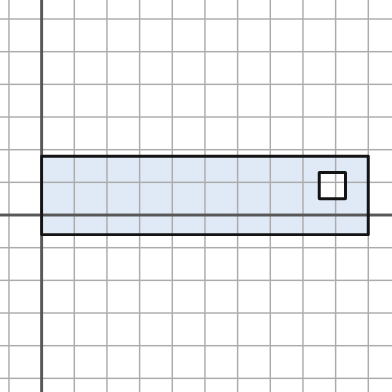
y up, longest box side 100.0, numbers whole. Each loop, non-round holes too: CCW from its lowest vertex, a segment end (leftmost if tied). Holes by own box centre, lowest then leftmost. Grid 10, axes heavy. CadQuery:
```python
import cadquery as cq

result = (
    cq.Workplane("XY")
    .moveTo(0.0, -6.0)
    .lineTo(100.0, -6.0)
    .lineTo(100.0, 18.0)
    .lineTo(0.0, 18.0)
    .close()
    .moveTo(85.0, 5.0)
    .lineTo(93.0, 5.0)
    .lineTo(93.0, 13.0)
    .lineTo(85.0, 13.0)
    .close()
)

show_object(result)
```